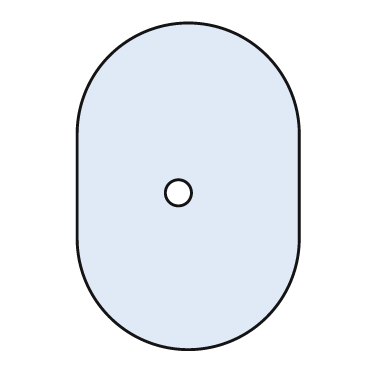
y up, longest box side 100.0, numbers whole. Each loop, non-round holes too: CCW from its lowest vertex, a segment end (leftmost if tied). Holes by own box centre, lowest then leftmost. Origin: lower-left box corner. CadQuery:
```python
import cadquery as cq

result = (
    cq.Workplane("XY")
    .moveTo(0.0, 34.0)
    .threePointArc((34.0, 0.0), (68.0, 34.0))
    .lineTo(68.0, 66.0)
    .threePointArc((34.0, 100.0), (0.0, 66.0))
    .close()
    .moveTo(31.0, 48.0)
    .circle(4.0)
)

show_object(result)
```